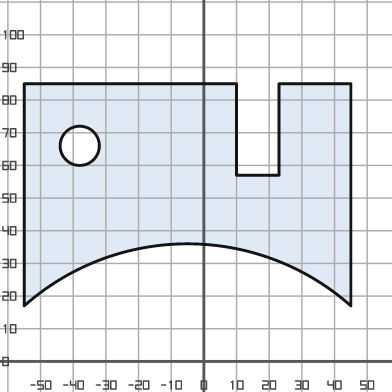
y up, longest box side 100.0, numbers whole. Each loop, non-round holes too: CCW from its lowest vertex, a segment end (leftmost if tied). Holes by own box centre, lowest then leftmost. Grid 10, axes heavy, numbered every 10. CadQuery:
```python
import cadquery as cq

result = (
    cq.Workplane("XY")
    .moveTo(-55.0, 17.0)
    .threePointArc((-5.0, 36.0), (45.0, 17.0))
    .lineTo(45.0, 85.0)
    .lineTo(23.0, 85.0)
    .lineTo(23.0, 57.0)
    .lineTo(10.0, 57.0)
    .lineTo(10.0, 85.0)
    .lineTo(-55.0, 85.0)
    .close()
    .moveTo(-38.0, 66.0)
    .circle(6.0)
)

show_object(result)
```